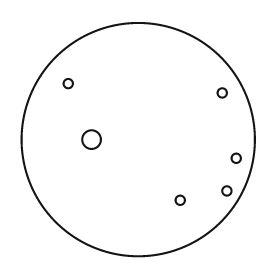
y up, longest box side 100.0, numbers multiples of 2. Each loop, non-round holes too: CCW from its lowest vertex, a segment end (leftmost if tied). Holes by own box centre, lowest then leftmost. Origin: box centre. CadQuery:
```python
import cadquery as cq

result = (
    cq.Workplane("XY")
    .moveTo(0.0, 0.0)
    .circle(50.0)
    .moveTo(18.0, -26.0)
    .circle(2.0)
    .moveTo(38.0, -22.0)
    .circle(2.0)
    .moveTo(42.0, -8.0)
    .circle(2.0)
    .moveTo(-20.0, 0.0)
    .circle(4.0)
    .moveTo(36.0, 20.0)
    .circle(2.0)
    .moveTo(-30.0, 24.0)
    .circle(2.0)
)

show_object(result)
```